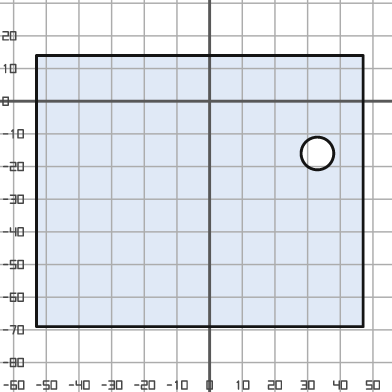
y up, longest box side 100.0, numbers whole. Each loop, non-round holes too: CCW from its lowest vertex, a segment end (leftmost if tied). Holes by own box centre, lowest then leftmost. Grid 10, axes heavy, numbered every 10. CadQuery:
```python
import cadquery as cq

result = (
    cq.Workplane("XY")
    .moveTo(-53.0, -69.0)
    .lineTo(47.0, -69.0)
    .lineTo(47.0, 14.0)
    .lineTo(-53.0, 14.0)
    .close()
    .moveTo(33.0, -16.0)
    .circle(5.0)
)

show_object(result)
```